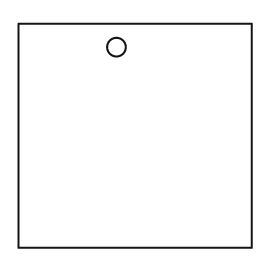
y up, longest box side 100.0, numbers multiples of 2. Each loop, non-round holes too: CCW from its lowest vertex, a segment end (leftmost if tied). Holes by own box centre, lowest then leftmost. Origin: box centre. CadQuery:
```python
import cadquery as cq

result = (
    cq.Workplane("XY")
    .moveTo(-50.0, -48.0)
    .lineTo(50.0, -48.0)
    .lineTo(50.0, 48.0)
    .lineTo(-50.0, 48.0)
    .close()
    .moveTo(-8.0, 38.0)
    .circle(4.0)
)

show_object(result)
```